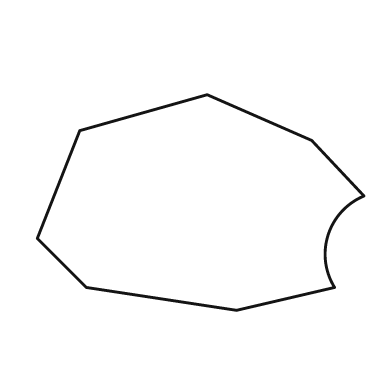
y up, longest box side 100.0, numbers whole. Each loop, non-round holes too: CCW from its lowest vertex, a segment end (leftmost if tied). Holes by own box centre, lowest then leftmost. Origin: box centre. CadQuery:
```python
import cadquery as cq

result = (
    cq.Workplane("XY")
    .moveTo(11.0, -33.0)
    .lineTo(41.0, -26.0)
    .threePointArc((39.0, -10.0), (50.0, 2.0))
    .lineTo(34.0, 19.0)
    .lineTo(2.0, 33.0)
    .lineTo(-37.0, 22.0)
    .lineTo(-50.0, -11.0)
    .lineTo(-35.0, -26.0)
    .close()
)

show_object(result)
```